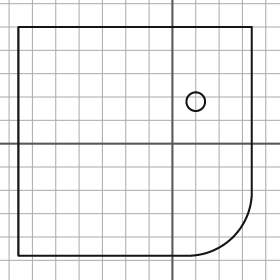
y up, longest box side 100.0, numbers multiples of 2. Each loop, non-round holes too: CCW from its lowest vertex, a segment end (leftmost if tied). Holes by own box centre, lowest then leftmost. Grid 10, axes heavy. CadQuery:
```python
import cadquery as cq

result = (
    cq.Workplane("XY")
    .moveTo(-66.0, -48.0)
    .lineTo(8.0, -48.0)
    .threePointArc((26.0, -40.0), (34.0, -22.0))
    .lineTo(34.0, 50.0)
    .lineTo(-66.0, 50.0)
    .close()
    .moveTo(10.0, 18.0)
    .circle(4.0)
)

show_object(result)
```